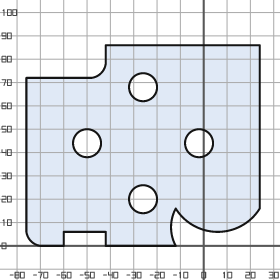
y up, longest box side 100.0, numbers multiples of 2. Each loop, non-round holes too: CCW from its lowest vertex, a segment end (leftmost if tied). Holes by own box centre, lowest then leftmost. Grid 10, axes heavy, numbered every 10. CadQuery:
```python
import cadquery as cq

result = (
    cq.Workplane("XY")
    .moveTo(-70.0, 0.0)
    .lineTo(-60.0, 0.0)
    .lineTo(-60.0, 6.0)
    .lineTo(-42.0, 6.0)
    .lineTo(-42.0, 0.0)
    .lineTo(-12.0, 0.0)
    .threePointArc((-14.0, 8.0), (-12.0, 16.0))
    .threePointArc((6.0, 6.0), (24.0, 16.0))
    .lineTo(24.0, 86.0)
    .lineTo(-42.0, 86.0)
    .lineTo(-42.0, 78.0)
    .threePointArc((-44.0, 74.0), (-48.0, 72.0))
    .lineTo(-76.0, 72.0)
    .lineTo(-76.0, 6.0)
    .threePointArc((-74.0, 2.0), (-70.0, 0.0))
    .close()
    .moveTo(-26.0, 20.0)
    .circle(6.0)
    .moveTo(-50.0, 44.0)
    .circle(6.0)
    .moveTo(-2.0, 44.0)
    .circle(6.0)
    .moveTo(-26.0, 68.0)
    .circle(6.0)
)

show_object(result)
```